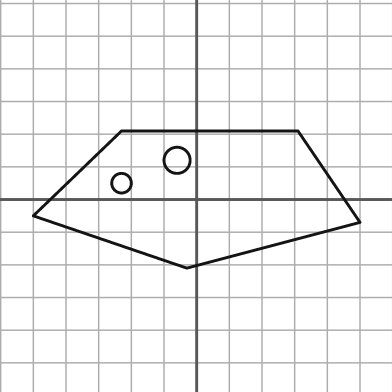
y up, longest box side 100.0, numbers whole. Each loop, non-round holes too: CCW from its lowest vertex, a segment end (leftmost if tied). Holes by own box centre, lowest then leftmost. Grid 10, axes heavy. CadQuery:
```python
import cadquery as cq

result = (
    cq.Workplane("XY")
    .moveTo(-3.0, -21.0)
    .lineTo(50.0, -7.0)
    .lineTo(31.0, 21.0)
    .lineTo(-23.0, 21.0)
    .lineTo(-50.0, -5.0)
    .close()
    .moveTo(-23.0, 5.0)
    .circle(3.0)
    .moveTo(-6.0, 12.0)
    .circle(4.0)
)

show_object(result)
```